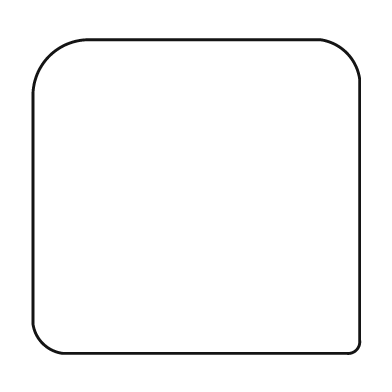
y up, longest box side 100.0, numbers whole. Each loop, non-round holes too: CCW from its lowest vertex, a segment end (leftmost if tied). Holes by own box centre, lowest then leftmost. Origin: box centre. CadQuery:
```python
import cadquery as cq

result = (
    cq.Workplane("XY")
    .moveTo(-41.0, -48.0)
    .lineTo(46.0, -48.0)
    .threePointArc((49.0, -47.0), (50.0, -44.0))
    .lineTo(50.0, 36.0)
    .threePointArc((46.0, 44.0), (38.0, 48.0))
    .lineTo(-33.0, 48.0)
    .threePointArc((-45.0, 43.0), (-50.0, 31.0))
    .lineTo(-50.0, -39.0)
    .threePointArc((-47.0, -45.0), (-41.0, -48.0))
    .close()
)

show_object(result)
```